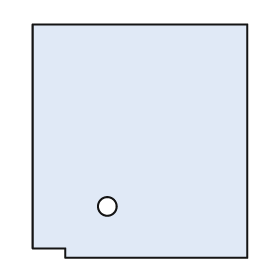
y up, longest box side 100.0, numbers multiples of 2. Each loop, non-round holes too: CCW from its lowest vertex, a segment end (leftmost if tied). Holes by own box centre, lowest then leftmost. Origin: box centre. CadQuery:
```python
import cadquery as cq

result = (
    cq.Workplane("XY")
    .moveTo(-32.0, -50.0)
    .lineTo(46.0, -50.0)
    .lineTo(46.0, 50.0)
    .lineTo(-46.0, 50.0)
    .lineTo(-46.0, -46.0)
    .lineTo(-32.0, -46.0)
    .close()
    .moveTo(-14.0, -28.0)
    .circle(4.0)
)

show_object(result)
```